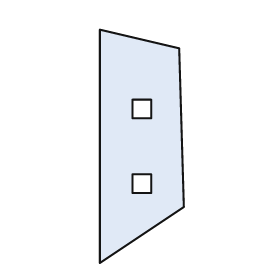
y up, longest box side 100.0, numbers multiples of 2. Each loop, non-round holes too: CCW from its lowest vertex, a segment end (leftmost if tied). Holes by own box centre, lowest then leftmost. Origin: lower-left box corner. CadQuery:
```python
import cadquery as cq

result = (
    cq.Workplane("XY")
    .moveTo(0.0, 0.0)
    .lineTo(36.0, 24.0)
    .lineTo(34.0, 92.0)
    .lineTo(0.0, 100.0)
    .close()
    .moveTo(14.0, 30.0)
    .lineTo(22.0, 30.0)
    .lineTo(22.0, 38.0)
    .lineTo(14.0, 38.0)
    .close()
    .moveTo(14.0, 62.0)
    .lineTo(22.0, 62.0)
    .lineTo(22.0, 70.0)
    .lineTo(14.0, 70.0)
    .close()
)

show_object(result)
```